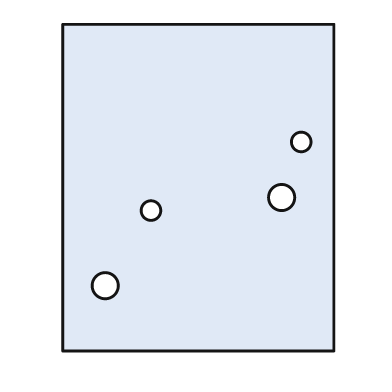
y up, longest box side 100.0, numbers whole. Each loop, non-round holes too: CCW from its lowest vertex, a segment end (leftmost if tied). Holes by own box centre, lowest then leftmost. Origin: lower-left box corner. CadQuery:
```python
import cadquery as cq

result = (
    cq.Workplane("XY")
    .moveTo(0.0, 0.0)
    .lineTo(83.0, 0.0)
    .lineTo(83.0, 100.0)
    .lineTo(0.0, 100.0)
    .close()
    .moveTo(13.0, 20.0)
    .circle(4.0)
    .moveTo(27.0, 43.0)
    .circle(3.0)
    .moveTo(67.0, 47.0)
    .circle(4.0)
    .moveTo(73.0, 64.0)
    .circle(3.0)
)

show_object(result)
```